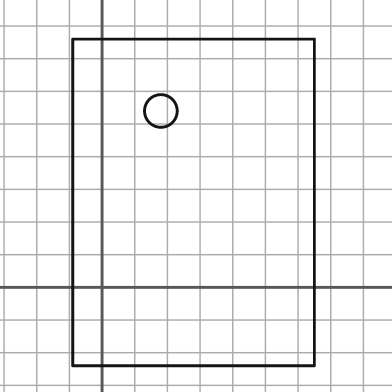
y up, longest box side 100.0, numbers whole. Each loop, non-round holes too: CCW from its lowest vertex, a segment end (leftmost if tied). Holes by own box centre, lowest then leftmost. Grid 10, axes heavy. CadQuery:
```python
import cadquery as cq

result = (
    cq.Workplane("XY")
    .moveTo(-9.0, -24.0)
    .lineTo(65.0, -24.0)
    .lineTo(65.0, 76.0)
    .lineTo(-9.0, 76.0)
    .close()
    .moveTo(18.0, 54.0)
    .circle(5.0)
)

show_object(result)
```